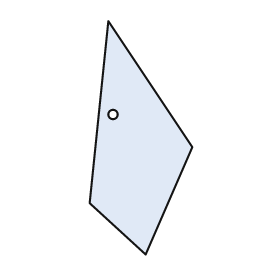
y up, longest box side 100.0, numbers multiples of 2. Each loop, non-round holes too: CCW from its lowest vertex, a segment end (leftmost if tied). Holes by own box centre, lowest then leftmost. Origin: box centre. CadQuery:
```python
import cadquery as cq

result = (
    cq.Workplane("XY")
    .moveTo(2.0, -50.0)
    .lineTo(22.0, -4.0)
    .lineTo(-14.0, 50.0)
    .lineTo(-22.0, -28.0)
    .close()
    .moveTo(-12.0, 10.0)
    .circle(2.0)
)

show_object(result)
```